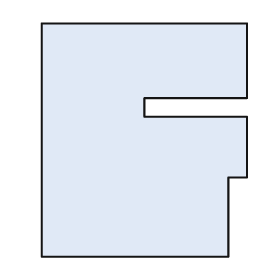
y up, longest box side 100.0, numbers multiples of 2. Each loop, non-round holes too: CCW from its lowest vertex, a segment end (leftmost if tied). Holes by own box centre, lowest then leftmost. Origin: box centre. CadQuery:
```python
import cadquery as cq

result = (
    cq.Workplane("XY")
    .moveTo(-44.0, -50.0)
    .lineTo(36.0, -50.0)
    .lineTo(36.0, -16.0)
    .lineTo(44.0, -16.0)
    .lineTo(44.0, 10.0)
    .lineTo(0.0, 10.0)
    .lineTo(0.0, 18.0)
    .lineTo(44.0, 18.0)
    .lineTo(44.0, 50.0)
    .lineTo(-44.0, 50.0)
    .close()
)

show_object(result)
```